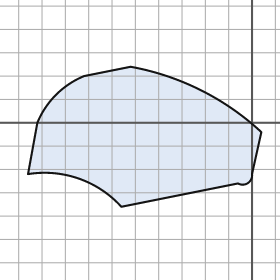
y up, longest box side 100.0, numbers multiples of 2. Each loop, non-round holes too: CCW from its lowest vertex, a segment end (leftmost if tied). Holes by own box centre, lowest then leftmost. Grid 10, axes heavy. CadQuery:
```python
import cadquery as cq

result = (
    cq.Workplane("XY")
    .moveTo(-56.0, -36.0)
    .lineTo(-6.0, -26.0)
    .threePointArc((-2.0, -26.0), (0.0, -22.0))
    .lineTo(4.0, -4.0)
    .threePointArc((-22.0, 14.0), (-52.0, 24.0))
    .lineTo(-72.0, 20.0)
    .threePointArc((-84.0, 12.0), (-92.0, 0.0))
    .lineTo(-96.0, -22.0)
    .threePointArc((-74.0, -24.0), (-56.0, -36.0))
    .close()
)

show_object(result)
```